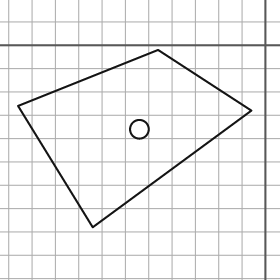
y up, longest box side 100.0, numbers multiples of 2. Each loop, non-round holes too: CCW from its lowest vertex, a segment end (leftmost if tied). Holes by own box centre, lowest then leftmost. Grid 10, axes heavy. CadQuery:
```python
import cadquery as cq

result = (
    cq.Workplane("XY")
    .moveTo(-74.0, -78.0)
    .lineTo(-6.0, -28.0)
    .lineTo(-46.0, -2.0)
    .lineTo(-106.0, -26.0)
    .close()
    .moveTo(-54.0, -36.0)
    .circle(4.0)
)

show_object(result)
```